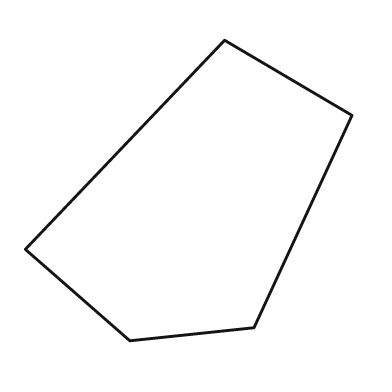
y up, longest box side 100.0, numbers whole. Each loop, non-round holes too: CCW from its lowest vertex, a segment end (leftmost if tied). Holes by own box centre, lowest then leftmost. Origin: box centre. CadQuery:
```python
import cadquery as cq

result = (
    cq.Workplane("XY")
    .moveTo(-18.0, -46.0)
    .lineTo(20.0, -42.0)
    .lineTo(50.0, 23.0)
    .lineTo(11.0, 46.0)
    .lineTo(-50.0, -18.0)
    .close()
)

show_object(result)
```